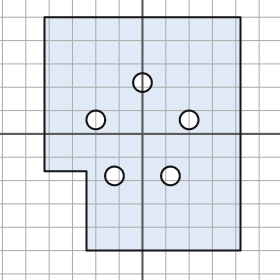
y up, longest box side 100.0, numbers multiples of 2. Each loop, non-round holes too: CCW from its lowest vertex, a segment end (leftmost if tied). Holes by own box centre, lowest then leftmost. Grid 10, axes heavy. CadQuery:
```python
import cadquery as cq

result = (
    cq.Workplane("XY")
    .moveTo(-24.0, -50.0)
    .lineTo(42.0, -50.0)
    .lineTo(42.0, 50.0)
    .lineTo(-42.0, 50.0)
    .lineTo(-42.0, -16.0)
    .lineTo(-24.0, -16.0)
    .close()
    .moveTo(-12.0, -18.0)
    .circle(4.0)
    .moveTo(12.0, -18.0)
    .circle(4.0)
    .moveTo(-20.0, 6.0)
    .circle(4.0)
    .moveTo(20.0, 6.0)
    .circle(4.0)
    .moveTo(0.0, 22.0)
    .circle(4.0)
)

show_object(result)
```